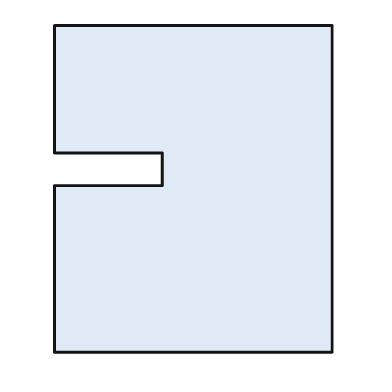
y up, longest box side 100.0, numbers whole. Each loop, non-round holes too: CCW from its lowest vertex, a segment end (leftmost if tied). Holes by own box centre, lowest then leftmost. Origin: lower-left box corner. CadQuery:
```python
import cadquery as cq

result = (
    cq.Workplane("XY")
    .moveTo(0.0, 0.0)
    .lineTo(85.0, 0.0)
    .lineTo(85.0, 100.0)
    .lineTo(0.0, 100.0)
    .lineTo(0.0, 61.0)
    .lineTo(33.0, 61.0)
    .lineTo(33.0, 51.0)
    .lineTo(0.0, 51.0)
    .close()
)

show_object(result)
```